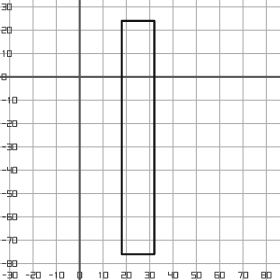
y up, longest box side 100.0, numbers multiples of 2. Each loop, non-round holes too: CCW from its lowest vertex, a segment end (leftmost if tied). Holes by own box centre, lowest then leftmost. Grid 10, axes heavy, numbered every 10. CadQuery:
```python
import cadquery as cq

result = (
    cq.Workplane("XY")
    .moveTo(18.0, -76.0)
    .lineTo(32.0, -76.0)
    .lineTo(32.0, 24.0)
    .lineTo(18.0, 24.0)
    .close()
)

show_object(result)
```